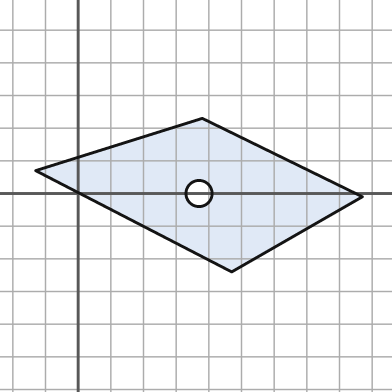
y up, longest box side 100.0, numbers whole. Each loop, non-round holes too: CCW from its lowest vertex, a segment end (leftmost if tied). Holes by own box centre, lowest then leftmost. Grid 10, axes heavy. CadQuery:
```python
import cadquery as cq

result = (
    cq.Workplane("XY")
    .moveTo(47.0, -24.0)
    .lineTo(87.0, -1.0)
    .lineTo(38.0, 23.0)
    .lineTo(-13.0, 7.0)
    .close()
    .moveTo(37.0, 0.0)
    .circle(4.0)
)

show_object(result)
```